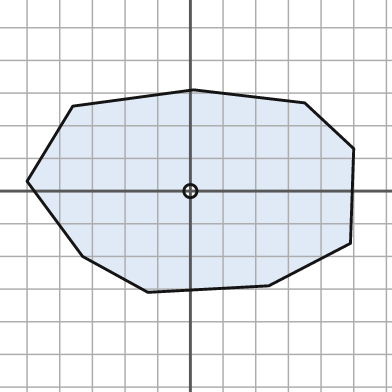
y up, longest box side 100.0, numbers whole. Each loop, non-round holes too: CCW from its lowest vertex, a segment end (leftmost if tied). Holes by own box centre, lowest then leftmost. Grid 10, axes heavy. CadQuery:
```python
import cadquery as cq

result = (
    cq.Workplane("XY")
    .moveTo(-13.0, -31.0)
    .lineTo(24.0, -29.0)
    .lineTo(49.0, -16.0)
    .lineTo(50.0, 13.0)
    .lineTo(35.0, 27.0)
    .lineTo(1.0, 31.0)
    .lineTo(-36.0, 26.0)
    .lineTo(-50.0, 3.0)
    .lineTo(-33.0, -20.0)
    .close()
    .moveTo(0.0, 0.0)
    .circle(2.0)
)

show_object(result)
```